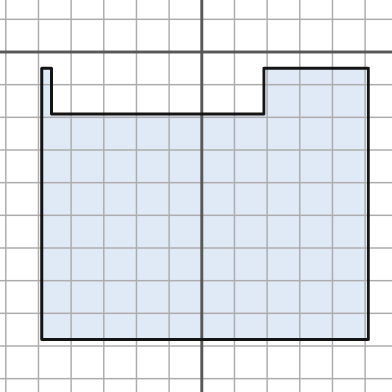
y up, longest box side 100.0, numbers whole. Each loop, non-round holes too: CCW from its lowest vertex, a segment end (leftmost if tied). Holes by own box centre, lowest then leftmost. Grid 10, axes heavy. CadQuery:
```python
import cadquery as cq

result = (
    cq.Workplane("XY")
    .moveTo(-49.0, -88.0)
    .lineTo(51.0, -88.0)
    .lineTo(51.0, -5.0)
    .lineTo(19.0, -5.0)
    .lineTo(19.0, -19.0)
    .lineTo(-46.0, -19.0)
    .lineTo(-46.0, -5.0)
    .lineTo(-49.0, -5.0)
    .close()
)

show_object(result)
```